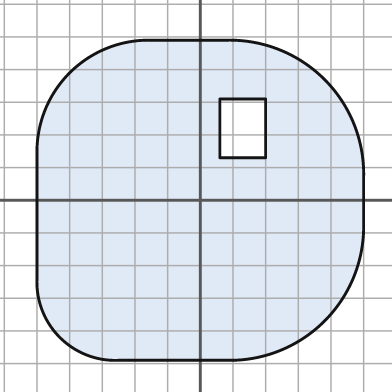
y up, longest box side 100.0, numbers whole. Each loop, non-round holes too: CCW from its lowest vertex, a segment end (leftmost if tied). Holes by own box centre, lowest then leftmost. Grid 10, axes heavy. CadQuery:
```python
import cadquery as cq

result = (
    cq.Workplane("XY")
    .moveTo(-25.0, -49.0)
    .lineTo(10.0, -49.0)
    .threePointArc((38.0, -37.0), (50.0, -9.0))
    .lineTo(50.0, 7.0)
    .threePointArc((38.0, 37.0), (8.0, 49.0))
    .lineTo(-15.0, 49.0)
    .threePointArc((-40.0, 39.0), (-50.0, 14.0))
    .lineTo(-50.0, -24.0)
    .threePointArc((-43.0, -42.0), (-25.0, -49.0))
    .close()
    .moveTo(6.0, 13.0)
    .lineTo(20.0, 13.0)
    .lineTo(20.0, 31.0)
    .lineTo(6.0, 31.0)
    .close()
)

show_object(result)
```